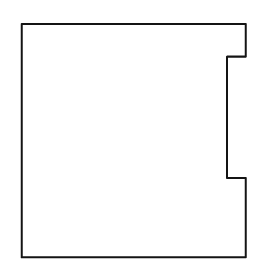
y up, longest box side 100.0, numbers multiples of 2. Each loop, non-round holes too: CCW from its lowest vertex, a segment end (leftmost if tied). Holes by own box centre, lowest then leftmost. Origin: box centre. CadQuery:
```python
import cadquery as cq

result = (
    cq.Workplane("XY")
    .moveTo(-48.0, -50.0)
    .lineTo(48.0, -50.0)
    .lineTo(48.0, -16.0)
    .lineTo(40.0, -16.0)
    .lineTo(40.0, 36.0)
    .lineTo(48.0, 36.0)
    .lineTo(48.0, 50.0)
    .lineTo(-48.0, 50.0)
    .close()
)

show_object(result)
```